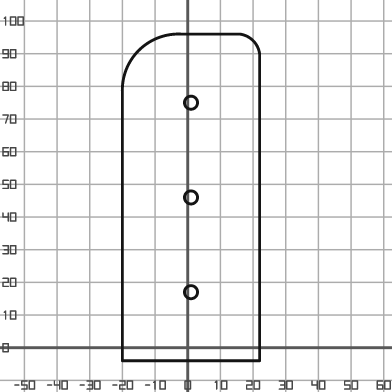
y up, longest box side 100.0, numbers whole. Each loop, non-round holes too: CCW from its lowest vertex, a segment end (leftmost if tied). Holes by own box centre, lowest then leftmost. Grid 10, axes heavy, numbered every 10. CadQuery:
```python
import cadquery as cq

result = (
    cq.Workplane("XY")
    .moveTo(-20.0, -4.0)
    .lineTo(22.0, -4.0)
    .lineTo(22.0, 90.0)
    .threePointArc((20.0, 94.0), (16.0, 96.0))
    .lineTo(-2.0, 96.0)
    .threePointArc((-15.0, 91.0), (-20.0, 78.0))
    .close()
    .moveTo(1.0, 17.0)
    .circle(2.0)
    .moveTo(1.0, 46.0)
    .circle(2.0)
    .moveTo(1.0, 75.0)
    .circle(2.0)
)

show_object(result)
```